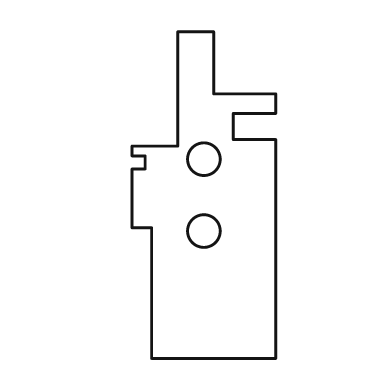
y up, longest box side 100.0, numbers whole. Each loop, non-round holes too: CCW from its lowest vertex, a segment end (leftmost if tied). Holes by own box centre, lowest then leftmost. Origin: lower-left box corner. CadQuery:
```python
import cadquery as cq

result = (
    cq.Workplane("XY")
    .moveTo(6.0, 0.0)
    .lineTo(44.0, 0.0)
    .lineTo(44.0, 67.0)
    .lineTo(31.0, 67.0)
    .lineTo(31.0, 75.0)
    .lineTo(44.0, 75.0)
    .lineTo(44.0, 81.0)
    .lineTo(25.0, 81.0)
    .lineTo(25.0, 100.0)
    .lineTo(14.0, 100.0)
    .lineTo(14.0, 65.0)
    .lineTo(0.0, 65.0)
    .lineTo(0.0, 62.0)
    .lineTo(4.0, 62.0)
    .lineTo(4.0, 58.0)
    .lineTo(0.0, 58.0)
    .lineTo(0.0, 40.0)
    .lineTo(6.0, 40.0)
    .close()
    .moveTo(22.0, 39.0)
    .circle(5.0)
    .moveTo(22.0, 61.0)
    .circle(5.0)
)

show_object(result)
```